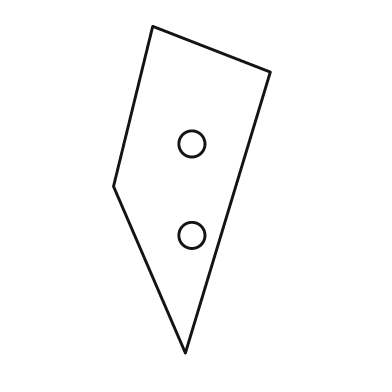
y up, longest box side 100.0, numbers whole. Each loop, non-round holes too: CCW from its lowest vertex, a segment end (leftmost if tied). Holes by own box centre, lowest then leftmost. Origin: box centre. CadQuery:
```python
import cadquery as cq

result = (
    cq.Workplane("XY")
    .moveTo(-2.0, -50.0)
    .lineTo(24.0, 36.0)
    .lineTo(-12.0, 50.0)
    .lineTo(-24.0, 1.0)
    .close()
    .moveTo(0.0, -14.0)
    .circle(4.0)
    .moveTo(0.0, 14.0)
    .circle(4.0)
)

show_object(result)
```